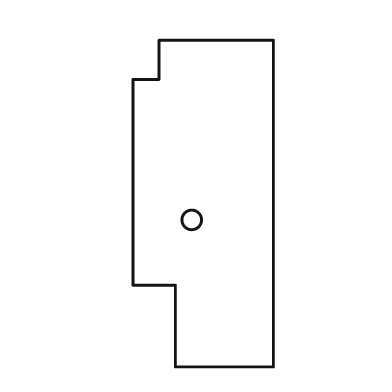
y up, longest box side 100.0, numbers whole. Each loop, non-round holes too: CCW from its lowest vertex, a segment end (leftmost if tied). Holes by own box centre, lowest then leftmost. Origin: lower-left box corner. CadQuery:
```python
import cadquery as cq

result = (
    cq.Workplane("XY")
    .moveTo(13.0, 0.0)
    .lineTo(43.0, 0.0)
    .lineTo(43.0, 100.0)
    .lineTo(8.0, 100.0)
    .lineTo(8.0, 88.0)
    .lineTo(0.0, 88.0)
    .lineTo(0.0, 25.0)
    .lineTo(13.0, 25.0)
    .close()
    .moveTo(18.0, 45.0)
    .circle(3.0)
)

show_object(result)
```